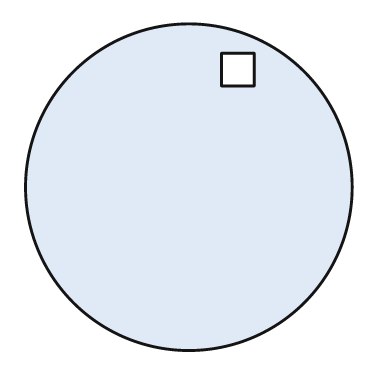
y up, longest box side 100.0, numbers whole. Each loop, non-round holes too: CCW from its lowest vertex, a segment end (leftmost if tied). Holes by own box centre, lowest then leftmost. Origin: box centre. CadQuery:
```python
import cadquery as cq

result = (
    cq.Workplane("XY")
    .moveTo(0.0, 0.0)
    .circle(50.0)
    .moveTo(10.0, 31.0)
    .lineTo(20.0, 31.0)
    .lineTo(20.0, 41.0)
    .lineTo(10.0, 41.0)
    .close()
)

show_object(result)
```